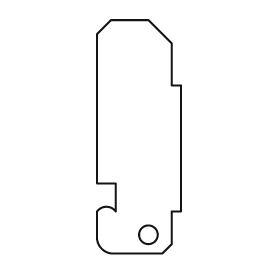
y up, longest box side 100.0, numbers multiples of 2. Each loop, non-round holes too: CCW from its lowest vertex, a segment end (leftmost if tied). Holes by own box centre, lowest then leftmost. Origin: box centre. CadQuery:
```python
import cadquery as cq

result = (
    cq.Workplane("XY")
    .moveTo(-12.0, -50.0)
    .lineTo(10.0, -50.0)
    .lineTo(14.0, -46.0)
    .lineTo(14.0, -32.0)
    .lineTo(18.0, -32.0)
    .lineTo(18.0, 22.0)
    .lineTo(14.0, 22.0)
    .lineTo(14.0, 40.0)
    .lineTo(4.0, 50.0)
    .lineTo(-12.0, 50.0)
    .lineTo(-18.0, 44.0)
    .lineTo(-18.0, -20.0)
    .lineTo(-10.0, -20.0)
    .lineTo(-10.0, -32.0)
    .threePointArc((-14.0, -30.0), (-18.0, -32.0))
    .lineTo(-18.0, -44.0)
    .threePointArc((-16.0, -48.0), (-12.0, -50.0))
    .close()
    .moveTo(4.0, -42.0)
    .circle(4.0)
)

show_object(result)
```